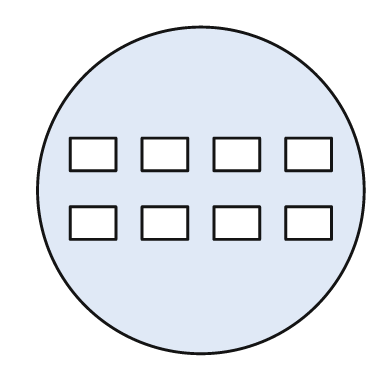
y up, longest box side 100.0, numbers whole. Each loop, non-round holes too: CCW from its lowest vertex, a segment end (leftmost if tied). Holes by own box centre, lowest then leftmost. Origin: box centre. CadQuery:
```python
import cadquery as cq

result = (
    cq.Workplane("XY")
    .moveTo(0.0, 0.0)
    .circle(50.0)
    .moveTo(-40.0, -15.0)
    .lineTo(-26.0, -15.0)
    .lineTo(-26.0, -5.0)
    .lineTo(-40.0, -5.0)
    .close()
    .moveTo(-18.0, -15.0)
    .lineTo(-4.0, -15.0)
    .lineTo(-4.0, -5.0)
    .lineTo(-18.0, -5.0)
    .close()
    .moveTo(4.0, -15.0)
    .lineTo(18.0, -15.0)
    .lineTo(18.0, -5.0)
    .lineTo(4.0, -5.0)
    .close()
    .moveTo(26.0, -15.0)
    .lineTo(40.0, -15.0)
    .lineTo(40.0, -5.0)
    .lineTo(26.0, -5.0)
    .close()
    .moveTo(-40.0, 6.0)
    .lineTo(-26.0, 6.0)
    .lineTo(-26.0, 16.0)
    .lineTo(-40.0, 16.0)
    .close()
    .moveTo(-18.0, 6.0)
    .lineTo(-4.0, 6.0)
    .lineTo(-4.0, 16.0)
    .lineTo(-18.0, 16.0)
    .close()
    .moveTo(4.0, 6.0)
    .lineTo(18.0, 6.0)
    .lineTo(18.0, 16.0)
    .lineTo(4.0, 16.0)
    .close()
    .moveTo(26.0, 6.0)
    .lineTo(40.0, 6.0)
    .lineTo(40.0, 16.0)
    .lineTo(26.0, 16.0)
    .close()
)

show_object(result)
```